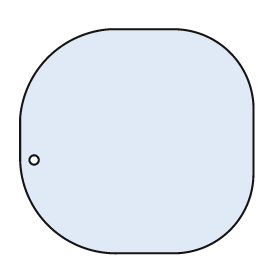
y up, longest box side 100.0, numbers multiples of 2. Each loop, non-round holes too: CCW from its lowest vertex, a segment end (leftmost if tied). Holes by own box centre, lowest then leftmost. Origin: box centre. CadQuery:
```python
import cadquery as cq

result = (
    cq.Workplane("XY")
    .moveTo(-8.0, -48.0)
    .lineTo(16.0, -48.0)
    .threePointArc((40.0, -38.0), (50.0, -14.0))
    .lineTo(50.0, 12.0)
    .threePointArc((40.0, 38.0), (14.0, 48.0))
    .lineTo(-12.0, 48.0)
    .threePointArc((-38.0, 36.0), (-50.0, 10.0))
    .lineTo(-50.0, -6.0)
    .threePointArc((-38.0, -36.0), (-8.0, -48.0))
    .close()
    .moveTo(-44.0, -8.0)
    .circle(2.0)
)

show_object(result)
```